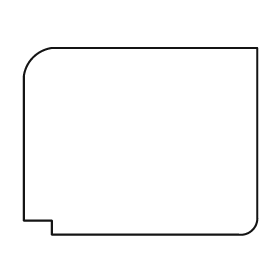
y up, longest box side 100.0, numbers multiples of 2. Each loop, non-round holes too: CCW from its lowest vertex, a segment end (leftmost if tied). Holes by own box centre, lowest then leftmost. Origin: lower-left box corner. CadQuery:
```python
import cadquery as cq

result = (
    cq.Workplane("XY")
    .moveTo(12.0, 0.0)
    .lineTo(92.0, 0.0)
    .threePointArc((98.0, 2.0), (100.0, 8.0))
    .lineTo(100.0, 80.0)
    .lineTo(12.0, 80.0)
    .threePointArc((4.0, 76.0), (0.0, 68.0))
    .lineTo(0.0, 6.0)
    .lineTo(12.0, 6.0)
    .close()
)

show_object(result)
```